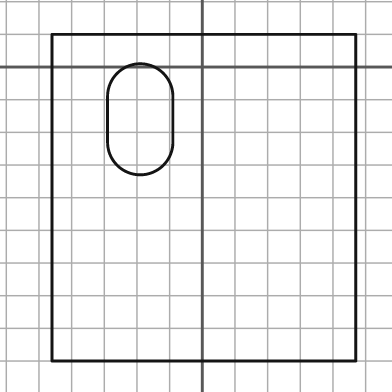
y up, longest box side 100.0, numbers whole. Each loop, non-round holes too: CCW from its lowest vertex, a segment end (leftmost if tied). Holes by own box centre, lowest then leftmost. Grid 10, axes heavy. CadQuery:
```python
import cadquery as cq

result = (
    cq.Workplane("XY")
    .moveTo(-46.0, -90.0)
    .lineTo(47.0, -90.0)
    .lineTo(47.0, 10.0)
    .lineTo(-46.0, 10.0)
    .close()
    .moveTo(-29.0, -23.0)
    .threePointArc((-19.0, -33.0), (-9.0, -23.0))
    .lineTo(-9.0, -9.0)
    .threePointArc((-19.0, 1.0), (-29.0, -9.0))
    .close()
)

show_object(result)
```